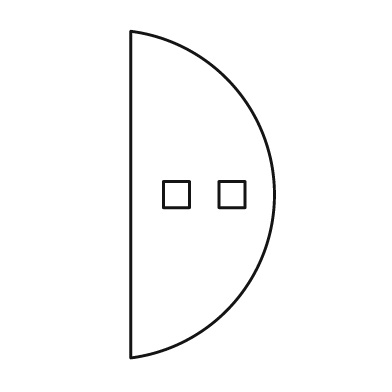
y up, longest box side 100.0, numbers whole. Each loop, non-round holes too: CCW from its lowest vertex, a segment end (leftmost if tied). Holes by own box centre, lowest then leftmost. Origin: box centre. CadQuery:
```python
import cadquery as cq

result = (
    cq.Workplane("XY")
    .moveTo(-22.0, -50.0)
    .threePointArc((22.0, 0.0), (-22.0, 50.0))
    .close()
    .moveTo(-12.0, -4.0)
    .lineTo(-4.0, -4.0)
    .lineTo(-4.0, 4.0)
    .lineTo(-12.0, 4.0)
    .close()
    .moveTo(5.0, -4.0)
    .lineTo(13.0, -4.0)
    .lineTo(13.0, 4.0)
    .lineTo(5.0, 4.0)
    .close()
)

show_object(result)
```